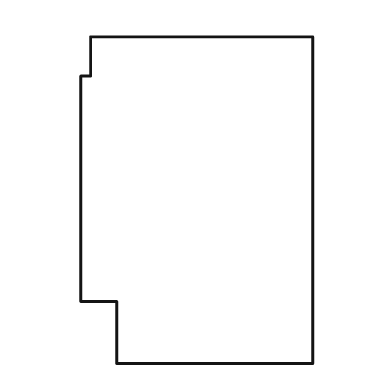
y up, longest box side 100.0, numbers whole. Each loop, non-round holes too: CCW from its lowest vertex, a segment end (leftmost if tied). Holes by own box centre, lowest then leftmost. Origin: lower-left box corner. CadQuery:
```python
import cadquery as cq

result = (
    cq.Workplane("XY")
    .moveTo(11.0, 0.0)
    .lineTo(71.0, 0.0)
    .lineTo(71.0, 100.0)
    .lineTo(3.0, 100.0)
    .lineTo(3.0, 88.0)
    .lineTo(0.0, 88.0)
    .lineTo(0.0, 19.0)
    .lineTo(11.0, 19.0)
    .close()
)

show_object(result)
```